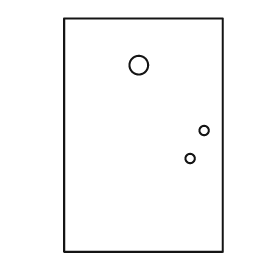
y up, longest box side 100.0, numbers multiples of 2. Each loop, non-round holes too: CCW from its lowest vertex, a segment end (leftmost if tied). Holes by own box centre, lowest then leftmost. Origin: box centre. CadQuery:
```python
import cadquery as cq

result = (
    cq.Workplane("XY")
    .moveTo(-34.0, -50.0)
    .lineTo(34.0, -50.0)
    .lineTo(34.0, 50.0)
    .lineTo(-34.0, 50.0)
    .close()
    .moveTo(20.0, -10.0)
    .circle(2.0)
    .moveTo(26.0, 2.0)
    .circle(2.0)
    .moveTo(-2.0, 30.0)
    .circle(4.0)
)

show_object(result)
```